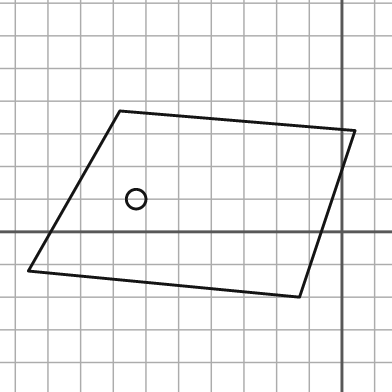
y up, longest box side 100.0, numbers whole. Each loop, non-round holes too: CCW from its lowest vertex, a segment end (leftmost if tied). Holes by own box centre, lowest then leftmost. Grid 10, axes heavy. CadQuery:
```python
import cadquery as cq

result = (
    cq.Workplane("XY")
    .moveTo(-13.0, -20.0)
    .lineTo(4.0, 31.0)
    .lineTo(-68.0, 37.0)
    .lineTo(-96.0, -12.0)
    .close()
    .moveTo(-63.0, 10.0)
    .circle(3.0)
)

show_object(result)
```